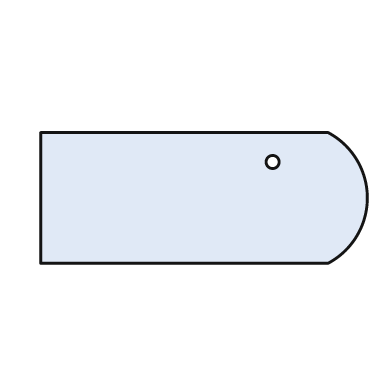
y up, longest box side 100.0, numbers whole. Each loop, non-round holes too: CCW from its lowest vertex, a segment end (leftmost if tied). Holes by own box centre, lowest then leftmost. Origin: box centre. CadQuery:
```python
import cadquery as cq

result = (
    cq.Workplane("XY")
    .moveTo(-50.0, -20.0)
    .lineTo(38.0, -20.0)
    .threePointArc((50.0, 0.0), (38.0, 20.0))
    .lineTo(-50.0, 20.0)
    .close()
    .moveTo(21.0, 11.0)
    .circle(2.0)
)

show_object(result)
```